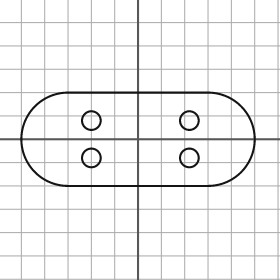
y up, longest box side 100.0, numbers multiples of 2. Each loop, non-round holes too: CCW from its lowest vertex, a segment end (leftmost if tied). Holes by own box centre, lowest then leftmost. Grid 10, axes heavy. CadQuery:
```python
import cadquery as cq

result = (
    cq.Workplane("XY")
    .moveTo(-30.0, -20.0)
    .lineTo(30.0, -20.0)
    .threePointArc((50.0, 0.0), (30.0, 20.0))
    .lineTo(-30.0, 20.0)
    .threePointArc((-50.0, 0.0), (-30.0, -20.0))
    .close()
    .moveTo(-20.0, -8.0)
    .circle(4.0)
    .moveTo(22.0, -8.0)
    .circle(4.0)
    .moveTo(-20.0, 8.0)
    .circle(4.0)
    .moveTo(22.0, 8.0)
    .circle(4.0)
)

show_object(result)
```